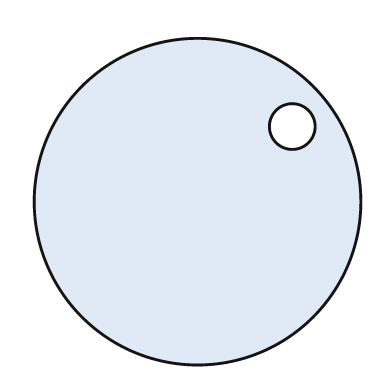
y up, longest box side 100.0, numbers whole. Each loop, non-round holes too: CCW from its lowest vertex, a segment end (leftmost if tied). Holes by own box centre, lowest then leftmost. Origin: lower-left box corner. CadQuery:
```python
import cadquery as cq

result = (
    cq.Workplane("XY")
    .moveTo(50.0, 50.0)
    .circle(50.0)
    .moveTo(79.0, 73.0)
    .circle(7.0)
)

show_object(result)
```